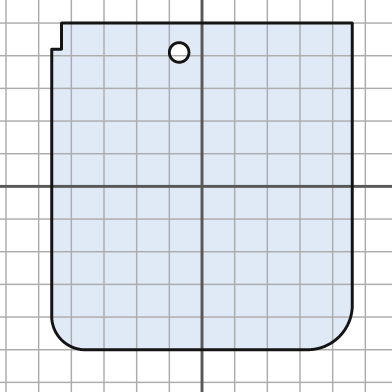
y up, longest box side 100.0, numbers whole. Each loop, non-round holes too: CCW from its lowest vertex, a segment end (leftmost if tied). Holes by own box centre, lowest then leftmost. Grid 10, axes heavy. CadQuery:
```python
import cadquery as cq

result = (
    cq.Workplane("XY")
    .moveTo(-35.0, -50.0)
    .lineTo(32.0, -50.0)
    .threePointArc((42.0, -46.0), (46.0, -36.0))
    .lineTo(46.0, 50.0)
    .lineTo(-43.0, 50.0)
    .lineTo(-43.0, 42.0)
    .lineTo(-46.0, 42.0)
    .lineTo(-46.0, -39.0)
    .threePointArc((-43.0, -47.0), (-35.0, -50.0))
    .close()
    .moveTo(-7.0, 41.0)
    .circle(3.0)
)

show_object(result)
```